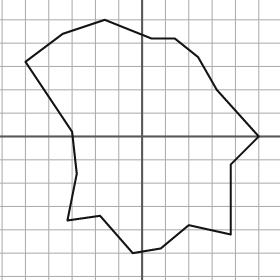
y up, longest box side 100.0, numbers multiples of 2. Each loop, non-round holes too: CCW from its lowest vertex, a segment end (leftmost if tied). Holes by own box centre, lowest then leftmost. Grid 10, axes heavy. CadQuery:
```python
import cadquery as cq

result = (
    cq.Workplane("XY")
    .moveTo(-4.0, -50.0)
    .lineTo(8.0, -48.0)
    .lineTo(20.0, -38.0)
    .lineTo(38.0, -42.0)
    .lineTo(38.0, -12.0)
    .lineTo(50.0, 0.0)
    .lineTo(32.0, 20.0)
    .lineTo(24.0, 34.0)
    .lineTo(14.0, 42.0)
    .lineTo(4.0, 42.0)
    .lineTo(-16.0, 50.0)
    .lineTo(-34.0, 44.0)
    .lineTo(-50.0, 32.0)
    .lineTo(-30.0, 2.0)
    .lineTo(-28.0, -16.0)
    .lineTo(-32.0, -36.0)
    .lineTo(-18.0, -34.0)
    .close()
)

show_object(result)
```